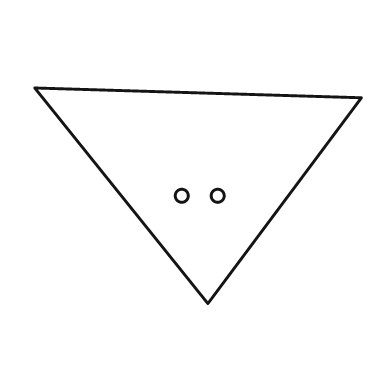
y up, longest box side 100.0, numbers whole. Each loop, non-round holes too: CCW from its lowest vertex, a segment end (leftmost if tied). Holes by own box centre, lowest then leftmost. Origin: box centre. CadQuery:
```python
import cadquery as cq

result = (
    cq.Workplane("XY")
    .moveTo(3.0, -33.0)
    .lineTo(50.0, 30.0)
    .lineTo(-50.0, 33.0)
    .close()
    .moveTo(-5.0, 0.0)
    .circle(2.0)
    .moveTo(6.0, 0.0)
    .circle(2.0)
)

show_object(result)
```